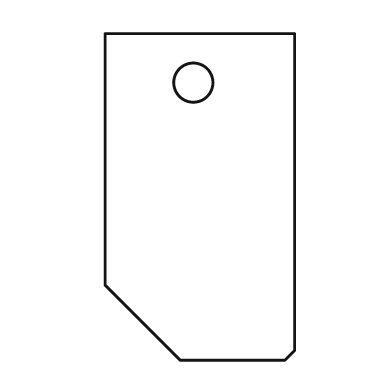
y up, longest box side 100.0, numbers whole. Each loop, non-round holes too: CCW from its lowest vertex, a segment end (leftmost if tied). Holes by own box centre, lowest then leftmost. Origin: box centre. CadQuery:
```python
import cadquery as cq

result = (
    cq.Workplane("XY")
    .moveTo(-6.0, -50.0)
    .lineTo(26.0, -50.0)
    .lineTo(29.0, -47.0)
    .lineTo(29.0, 50.0)
    .lineTo(-29.0, 50.0)
    .lineTo(-29.0, -27.0)
    .close()
    .moveTo(-2.0, 35.0)
    .circle(6.0)
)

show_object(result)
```